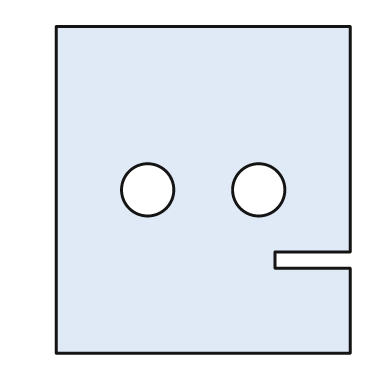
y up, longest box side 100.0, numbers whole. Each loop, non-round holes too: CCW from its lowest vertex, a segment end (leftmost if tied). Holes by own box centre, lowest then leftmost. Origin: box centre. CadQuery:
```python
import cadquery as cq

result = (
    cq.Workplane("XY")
    .moveTo(-45.0, -50.0)
    .lineTo(45.0, -50.0)
    .lineTo(45.0, -24.0)
    .lineTo(22.0, -24.0)
    .lineTo(22.0, -19.0)
    .lineTo(45.0, -19.0)
    .lineTo(45.0, 50.0)
    .lineTo(-45.0, 50.0)
    .close()
    .moveTo(-17.0, 0.0)
    .circle(8.0)
    .moveTo(17.0, 0.0)
    .circle(8.0)
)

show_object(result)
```